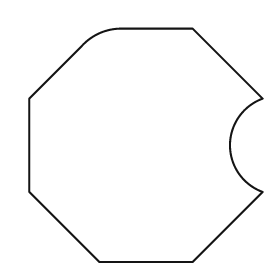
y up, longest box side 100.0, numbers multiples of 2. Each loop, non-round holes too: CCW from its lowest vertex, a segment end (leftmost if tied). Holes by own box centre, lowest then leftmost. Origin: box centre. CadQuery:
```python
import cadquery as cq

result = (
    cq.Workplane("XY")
    .moveTo(-20.0, -50.0)
    .lineTo(20.0, -50.0)
    .lineTo(50.0, -20.0)
    .threePointArc((36.0, 0.0), (50.0, 20.0))
    .lineTo(20.0, 50.0)
    .lineTo(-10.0, 50.0)
    .threePointArc((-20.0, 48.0), (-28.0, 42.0))
    .lineTo(-50.0, 20.0)
    .lineTo(-50.0, -20.0)
    .close()
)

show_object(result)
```